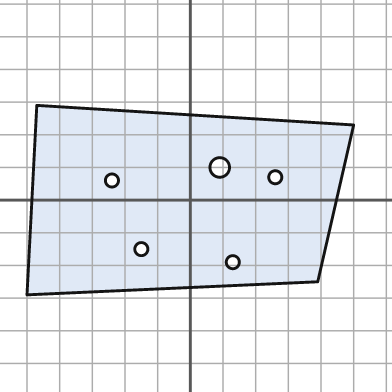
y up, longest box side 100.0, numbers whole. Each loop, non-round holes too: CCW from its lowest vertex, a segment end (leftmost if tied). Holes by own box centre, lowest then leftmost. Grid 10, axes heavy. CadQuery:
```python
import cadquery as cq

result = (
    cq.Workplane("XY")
    .moveTo(-50.0, -29.0)
    .lineTo(39.0, -25.0)
    .lineTo(50.0, 23.0)
    .lineTo(-47.0, 29.0)
    .close()
    .moveTo(13.0, -19.0)
    .circle(2.0)
    .moveTo(-15.0, -15.0)
    .circle(2.0)
    .moveTo(-24.0, 6.0)
    .circle(2.0)
    .moveTo(26.0, 7.0)
    .circle(2.0)
    .moveTo(9.0, 10.0)
    .circle(3.0)
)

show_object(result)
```